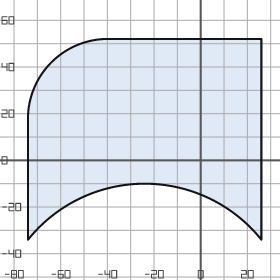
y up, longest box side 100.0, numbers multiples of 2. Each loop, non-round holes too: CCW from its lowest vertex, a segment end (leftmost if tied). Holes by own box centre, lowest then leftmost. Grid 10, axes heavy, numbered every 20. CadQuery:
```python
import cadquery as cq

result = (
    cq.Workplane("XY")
    .moveTo(-74.0, -34.0)
    .threePointArc((-24.0, -10.0), (26.0, -34.0))
    .lineTo(26.0, 52.0)
    .lineTo(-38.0, 52.0)
    .threePointArc((-64.0, 42.0), (-74.0, 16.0))
    .close()
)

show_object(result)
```